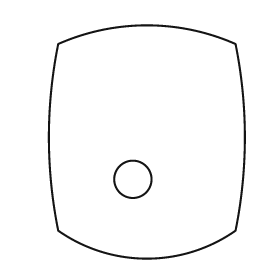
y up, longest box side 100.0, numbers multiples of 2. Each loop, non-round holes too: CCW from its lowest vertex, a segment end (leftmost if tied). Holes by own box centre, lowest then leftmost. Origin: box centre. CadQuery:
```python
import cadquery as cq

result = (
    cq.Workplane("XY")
    .moveTo(-38.0, -38.0)
    .threePointArc((0.0, -50.0), (38.0, -38.0))
    .threePointArc((42.0, 2.0), (38.0, 42.0))
    .threePointArc((0.0, 50.0), (-38.0, 42.0))
    .threePointArc((-42.0, 2.0), (-38.0, -38.0))
    .close()
    .moveTo(-6.0, -16.0)
    .circle(8.0)
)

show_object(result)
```